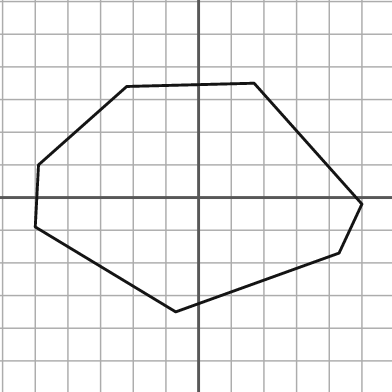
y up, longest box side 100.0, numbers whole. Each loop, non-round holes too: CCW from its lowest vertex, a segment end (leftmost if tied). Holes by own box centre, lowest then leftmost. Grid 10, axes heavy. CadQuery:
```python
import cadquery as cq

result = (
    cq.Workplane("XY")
    .moveTo(-7.0, -35.0)
    .lineTo(43.0, -17.0)
    .lineTo(50.0, -2.0)
    .lineTo(17.0, 35.0)
    .lineTo(-22.0, 34.0)
    .lineTo(-49.0, 10.0)
    .lineTo(-50.0, -9.0)
    .close()
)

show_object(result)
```